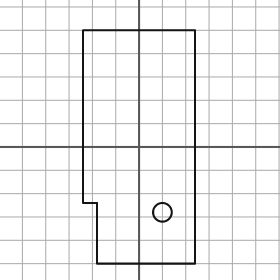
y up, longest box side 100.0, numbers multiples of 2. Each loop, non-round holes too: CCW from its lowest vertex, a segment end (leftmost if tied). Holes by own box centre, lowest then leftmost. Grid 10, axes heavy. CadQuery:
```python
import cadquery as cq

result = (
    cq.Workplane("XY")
    .moveTo(-18.0, -50.0)
    .lineTo(24.0, -50.0)
    .lineTo(24.0, 50.0)
    .lineTo(-24.0, 50.0)
    .lineTo(-24.0, -24.0)
    .lineTo(-18.0, -24.0)
    .close()
    .moveTo(10.0, -28.0)
    .circle(4.0)
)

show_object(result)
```